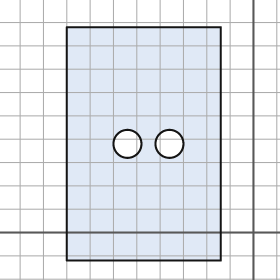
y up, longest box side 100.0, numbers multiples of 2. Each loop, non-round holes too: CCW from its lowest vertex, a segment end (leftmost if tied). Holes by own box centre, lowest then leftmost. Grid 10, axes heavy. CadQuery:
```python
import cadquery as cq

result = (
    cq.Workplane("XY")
    .moveTo(-80.0, -12.0)
    .lineTo(-14.0, -12.0)
    .lineTo(-14.0, 88.0)
    .lineTo(-80.0, 88.0)
    .close()
    .moveTo(-54.0, 38.0)
    .circle(6.0)
    .moveTo(-36.0, 38.0)
    .circle(6.0)
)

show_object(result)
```